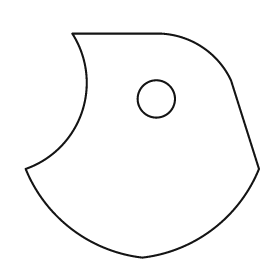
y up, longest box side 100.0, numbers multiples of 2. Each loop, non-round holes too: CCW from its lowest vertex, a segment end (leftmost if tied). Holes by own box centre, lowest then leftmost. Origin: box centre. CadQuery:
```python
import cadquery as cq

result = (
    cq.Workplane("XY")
    .moveTo(0.0, -48.0)
    .threePointArc((30.0, -36.0), (50.0, -10.0))
    .lineTo(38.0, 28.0)
    .threePointArc((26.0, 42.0), (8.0, 48.0))
    .lineTo(-30.0, 48.0)
    .threePointArc((-26.0, 14.0), (-50.0, -10.0))
    .threePointArc((-30.0, -36.0), (0.0, -48.0))
    .close()
    .moveTo(6.0, 20.0)
    .circle(8.0)
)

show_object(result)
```